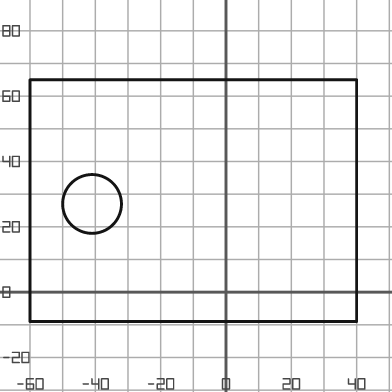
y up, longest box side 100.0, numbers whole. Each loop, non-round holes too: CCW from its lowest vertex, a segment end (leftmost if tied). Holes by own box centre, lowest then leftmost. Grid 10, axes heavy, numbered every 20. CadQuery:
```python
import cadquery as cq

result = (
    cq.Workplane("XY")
    .moveTo(-60.0, -9.0)
    .lineTo(40.0, -9.0)
    .lineTo(40.0, 65.0)
    .lineTo(-60.0, 65.0)
    .close()
    .moveTo(-41.0, 27.0)
    .circle(9.0)
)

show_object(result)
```